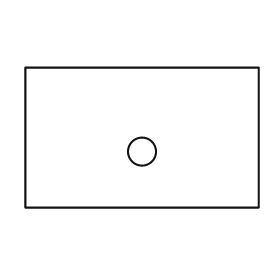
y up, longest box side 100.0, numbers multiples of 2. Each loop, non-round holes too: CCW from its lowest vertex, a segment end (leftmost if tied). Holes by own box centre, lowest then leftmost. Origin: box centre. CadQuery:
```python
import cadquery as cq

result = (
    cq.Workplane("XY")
    .moveTo(-50.0, -30.0)
    .lineTo(50.0, -30.0)
    .lineTo(50.0, 30.0)
    .lineTo(-50.0, 30.0)
    .close()
    .moveTo(0.0, -6.0)
    .circle(6.0)
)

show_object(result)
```